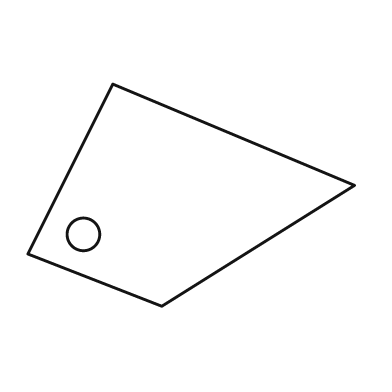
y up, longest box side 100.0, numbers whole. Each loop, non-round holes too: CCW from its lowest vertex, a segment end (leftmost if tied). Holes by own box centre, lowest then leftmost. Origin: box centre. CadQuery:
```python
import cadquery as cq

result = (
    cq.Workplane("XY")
    .moveTo(-9.0, -34.0)
    .lineTo(50.0, 3.0)
    .lineTo(-24.0, 34.0)
    .lineTo(-50.0, -18.0)
    .close()
    .moveTo(-33.0, -12.0)
    .circle(5.0)
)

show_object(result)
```